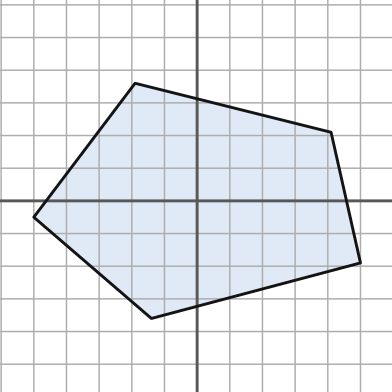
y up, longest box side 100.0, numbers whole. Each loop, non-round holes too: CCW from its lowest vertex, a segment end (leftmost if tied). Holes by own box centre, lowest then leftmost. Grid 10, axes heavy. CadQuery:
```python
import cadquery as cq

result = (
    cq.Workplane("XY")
    .moveTo(-14.0, -36.0)
    .lineTo(50.0, -19.0)
    .lineTo(41.0, 21.0)
    .lineTo(-19.0, 36.0)
    .lineTo(-50.0, -5.0)
    .close()
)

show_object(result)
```